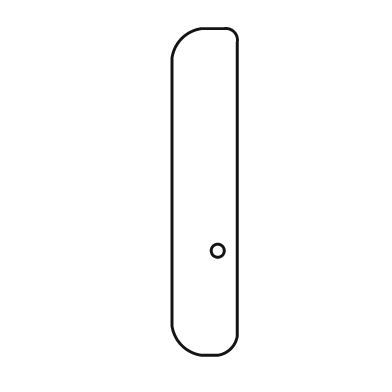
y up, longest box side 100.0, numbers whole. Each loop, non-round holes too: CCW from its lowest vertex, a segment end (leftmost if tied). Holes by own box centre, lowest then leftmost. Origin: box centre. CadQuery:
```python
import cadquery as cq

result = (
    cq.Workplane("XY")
    .moveTo(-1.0, -50.0)
    .lineTo(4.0, -50.0)
    .threePointArc((8.0, -48.0), (10.0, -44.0))
    .lineTo(10.0, 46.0)
    .threePointArc((9.0, 49.0), (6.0, 50.0))
    .lineTo(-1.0, 50.0)
    .threePointArc((-7.0, 47.0), (-10.0, 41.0))
    .lineTo(-10.0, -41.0)
    .threePointArc((-7.0, -47.0), (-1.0, -50.0))
    .close()
    .moveTo(4.0, -18.0)
    .circle(2.0)
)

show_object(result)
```